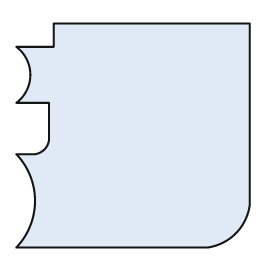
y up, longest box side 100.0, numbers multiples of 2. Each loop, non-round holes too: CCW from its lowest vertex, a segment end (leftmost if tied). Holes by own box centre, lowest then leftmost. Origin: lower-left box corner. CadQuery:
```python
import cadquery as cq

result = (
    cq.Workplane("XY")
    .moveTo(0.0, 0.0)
    .lineTo(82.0, 0.0)
    .threePointArc((94.0, 6.0), (100.0, 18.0))
    .lineTo(100.0, 96.0)
    .lineTo(16.0, 96.0)
    .lineTo(16.0, 86.0)
    .lineTo(0.0, 86.0)
    .threePointArc((6.0, 74.0), (0.0, 62.0))
    .lineTo(14.0, 62.0)
    .lineTo(14.0, 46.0)
    .threePointArc((12.0, 42.0), (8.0, 40.0))
    .lineTo(0.0, 40.0)
    .threePointArc((8.0, 20.0), (0.0, 0.0))
    .close()
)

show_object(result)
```